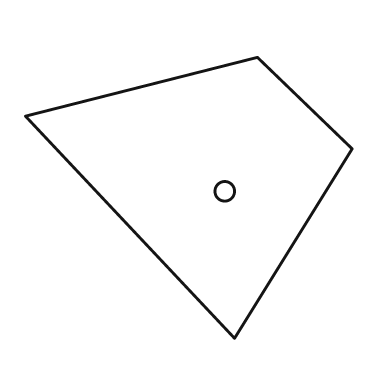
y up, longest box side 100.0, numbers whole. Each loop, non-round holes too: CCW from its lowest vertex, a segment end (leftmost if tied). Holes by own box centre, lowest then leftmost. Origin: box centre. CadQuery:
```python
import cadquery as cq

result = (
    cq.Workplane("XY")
    .moveTo(14.0, -43.0)
    .lineTo(50.0, 15.0)
    .lineTo(21.0, 43.0)
    .lineTo(-50.0, 25.0)
    .close()
    .moveTo(11.0, 2.0)
    .circle(3.0)
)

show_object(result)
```